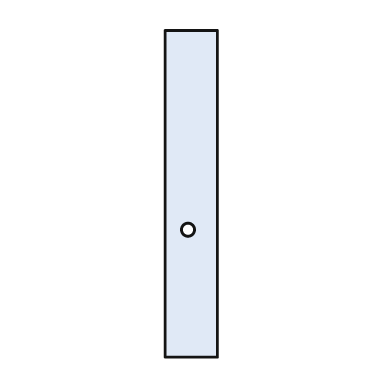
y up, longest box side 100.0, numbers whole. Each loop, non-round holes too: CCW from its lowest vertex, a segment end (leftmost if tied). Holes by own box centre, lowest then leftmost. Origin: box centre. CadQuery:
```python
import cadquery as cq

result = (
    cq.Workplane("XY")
    .moveTo(-8.0, -50.0)
    .lineTo(8.0, -50.0)
    .lineTo(8.0, 50.0)
    .lineTo(-8.0, 50.0)
    .close()
    .moveTo(-1.0, -11.0)
    .circle(2.0)
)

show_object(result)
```